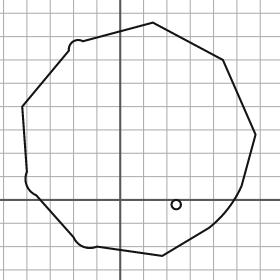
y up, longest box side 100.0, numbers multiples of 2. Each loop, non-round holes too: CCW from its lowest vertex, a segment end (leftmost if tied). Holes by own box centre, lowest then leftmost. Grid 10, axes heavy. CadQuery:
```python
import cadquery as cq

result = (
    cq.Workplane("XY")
    .moveTo(18.0, -24.0)
    .lineTo(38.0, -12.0)
    .threePointArc((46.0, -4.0), (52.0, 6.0))
    .lineTo(58.0, 28.0)
    .lineTo(44.0, 60.0)
    .lineTo(14.0, 76.0)
    .lineTo(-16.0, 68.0)
    .threePointArc((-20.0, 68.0), (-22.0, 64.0))
    .lineTo(-42.0, 40.0)
    .lineTo(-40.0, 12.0)
    .threePointArc((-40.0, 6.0), (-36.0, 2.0))
    .lineTo(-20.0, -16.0)
    .threePointArc((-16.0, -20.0), (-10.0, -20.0))
    .close()
    .moveTo(24.0, -2.0)
    .circle(2.0)
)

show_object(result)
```